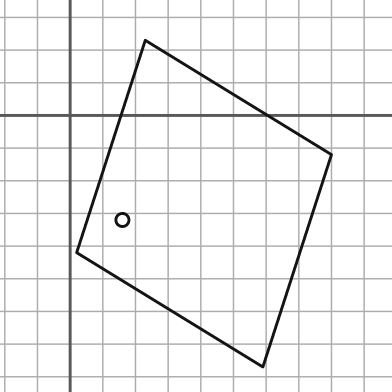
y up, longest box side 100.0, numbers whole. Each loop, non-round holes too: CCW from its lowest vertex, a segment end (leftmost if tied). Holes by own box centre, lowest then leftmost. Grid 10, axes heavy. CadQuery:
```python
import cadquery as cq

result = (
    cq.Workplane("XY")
    .moveTo(59.0, -77.0)
    .lineTo(80.0, -12.0)
    .lineTo(23.0, 23.0)
    .lineTo(2.0, -42.0)
    .close()
    .moveTo(16.0, -32.0)
    .circle(2.0)
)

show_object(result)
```